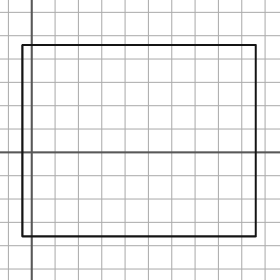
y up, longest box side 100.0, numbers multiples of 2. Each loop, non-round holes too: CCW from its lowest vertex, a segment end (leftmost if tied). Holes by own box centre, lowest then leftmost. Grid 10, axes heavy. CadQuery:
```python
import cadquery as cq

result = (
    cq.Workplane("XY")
    .moveTo(-4.0, -36.0)
    .lineTo(96.0, -36.0)
    .lineTo(96.0, 46.0)
    .lineTo(-4.0, 46.0)
    .close()
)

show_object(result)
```